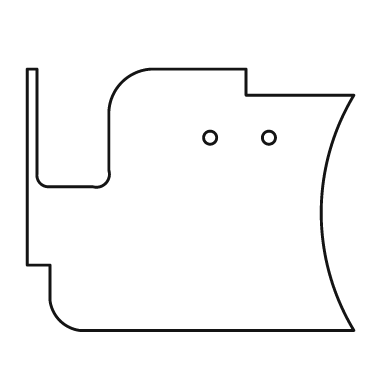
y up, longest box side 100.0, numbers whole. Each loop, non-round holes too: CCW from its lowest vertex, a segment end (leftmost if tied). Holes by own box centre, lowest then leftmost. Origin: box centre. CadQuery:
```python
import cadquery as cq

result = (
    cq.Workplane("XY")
    .moveTo(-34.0, -40.0)
    .lineTo(50.0, -40.0)
    .threePointArc((40.0, -4.0), (50.0, 32.0))
    .lineTo(17.0, 32.0)
    .lineTo(17.0, 40.0)
    .lineTo(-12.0, 40.0)
    .threePointArc((-21.0, 36.0), (-25.0, 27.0))
    .lineTo(-25.0, 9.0)
    .threePointArc((-26.0, 5.0), (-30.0, 4.0))
    .lineTo(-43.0, 4.0)
    .threePointArc((-46.0, 5.0), (-47.0, 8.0))
    .lineTo(-47.0, 40.0)
    .lineTo(-50.0, 40.0)
    .lineTo(-50.0, -20.0)
    .lineTo(-43.0, -20.0)
    .lineTo(-43.0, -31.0)
    .threePointArc((-40.0, -37.0), (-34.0, -40.0))
    .close()
    .moveTo(6.0, 19.0)
    .circle(2.0)
    .moveTo(24.0, 19.0)
    .circle(2.0)
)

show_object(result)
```